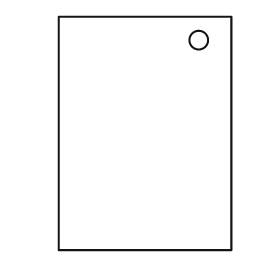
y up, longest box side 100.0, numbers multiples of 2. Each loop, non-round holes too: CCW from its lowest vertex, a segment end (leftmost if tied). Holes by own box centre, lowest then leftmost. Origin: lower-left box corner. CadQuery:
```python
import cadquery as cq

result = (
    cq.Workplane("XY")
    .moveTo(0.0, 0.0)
    .lineTo(74.0, 0.0)
    .lineTo(74.0, 100.0)
    .lineTo(0.0, 100.0)
    .close()
    .moveTo(60.0, 90.0)
    .circle(4.0)
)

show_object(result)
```